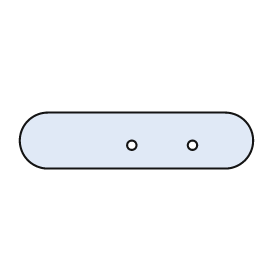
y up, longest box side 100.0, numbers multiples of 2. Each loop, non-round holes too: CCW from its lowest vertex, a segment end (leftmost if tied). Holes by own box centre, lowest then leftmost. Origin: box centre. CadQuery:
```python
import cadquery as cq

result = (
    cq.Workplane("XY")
    .moveTo(-38.0, -12.0)
    .lineTo(38.0, -12.0)
    .threePointArc((50.0, 0.0), (38.0, 12.0))
    .lineTo(-38.0, 12.0)
    .threePointArc((-50.0, 0.0), (-38.0, -12.0))
    .close()
    .moveTo(-2.0, -2.0)
    .circle(2.0)
    .moveTo(24.0, -2.0)
    .circle(2.0)
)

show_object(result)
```